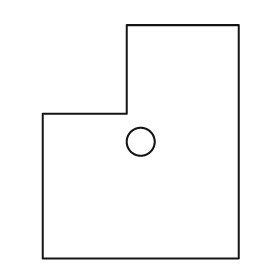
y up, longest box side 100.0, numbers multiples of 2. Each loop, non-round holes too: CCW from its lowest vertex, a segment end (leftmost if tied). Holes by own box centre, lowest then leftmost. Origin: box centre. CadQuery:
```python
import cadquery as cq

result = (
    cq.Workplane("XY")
    .moveTo(-42.0, -50.0)
    .lineTo(42.0, -50.0)
    .lineTo(42.0, 50.0)
    .lineTo(-6.0, 50.0)
    .lineTo(-6.0, 12.0)
    .lineTo(-42.0, 12.0)
    .close()
    .moveTo(0.0, 0.0)
    .circle(6.0)
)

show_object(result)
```